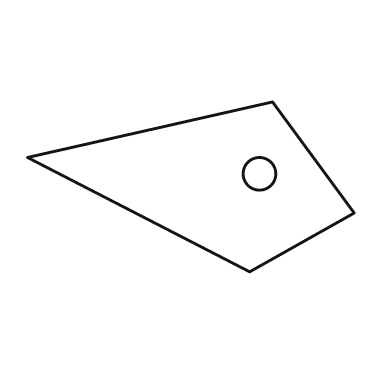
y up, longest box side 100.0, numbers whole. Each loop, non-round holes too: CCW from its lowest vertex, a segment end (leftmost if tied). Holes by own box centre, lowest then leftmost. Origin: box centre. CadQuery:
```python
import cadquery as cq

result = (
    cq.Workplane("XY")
    .moveTo(18.0, -26.0)
    .lineTo(50.0, -8.0)
    .lineTo(25.0, 26.0)
    .lineTo(-50.0, 9.0)
    .close()
    .moveTo(21.0, 4.0)
    .circle(5.0)
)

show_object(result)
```